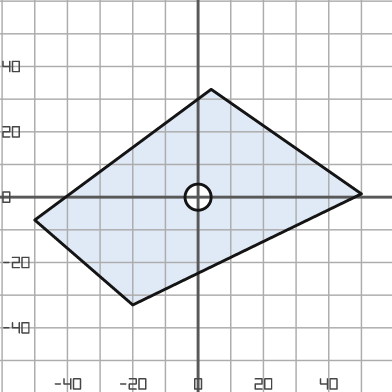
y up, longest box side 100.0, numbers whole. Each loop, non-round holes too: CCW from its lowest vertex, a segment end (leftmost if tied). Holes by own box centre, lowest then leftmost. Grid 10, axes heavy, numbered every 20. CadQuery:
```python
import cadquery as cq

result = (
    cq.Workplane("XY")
    .moveTo(-20.0, -33.0)
    .lineTo(50.0, 1.0)
    .lineTo(4.0, 33.0)
    .lineTo(-50.0, -7.0)
    .close()
    .moveTo(0.0, 0.0)
    .circle(4.0)
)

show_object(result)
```